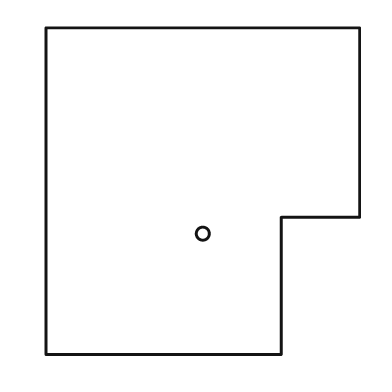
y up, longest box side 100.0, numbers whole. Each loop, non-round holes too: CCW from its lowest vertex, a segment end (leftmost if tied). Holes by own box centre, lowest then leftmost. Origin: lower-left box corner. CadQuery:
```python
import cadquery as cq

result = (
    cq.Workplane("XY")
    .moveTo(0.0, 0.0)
    .lineTo(72.0, 0.0)
    .lineTo(72.0, 42.0)
    .lineTo(96.0, 42.0)
    .lineTo(96.0, 100.0)
    .lineTo(0.0, 100.0)
    .close()
    .moveTo(48.0, 37.0)
    .circle(2.0)
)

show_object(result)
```